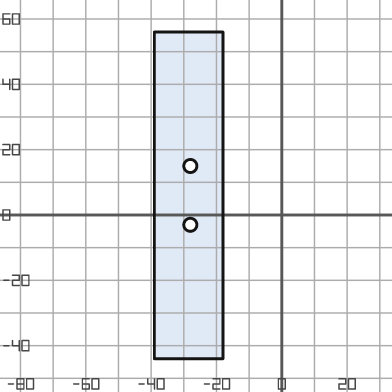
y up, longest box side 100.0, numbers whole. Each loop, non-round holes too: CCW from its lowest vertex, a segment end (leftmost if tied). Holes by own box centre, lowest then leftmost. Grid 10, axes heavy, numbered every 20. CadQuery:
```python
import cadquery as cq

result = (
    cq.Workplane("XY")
    .moveTo(-39.0, -44.0)
    .lineTo(-18.0, -44.0)
    .lineTo(-18.0, 56.0)
    .lineTo(-39.0, 56.0)
    .close()
    .moveTo(-28.0, -3.0)
    .circle(2.0)
    .moveTo(-28.0, 15.0)
    .circle(2.0)
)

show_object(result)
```